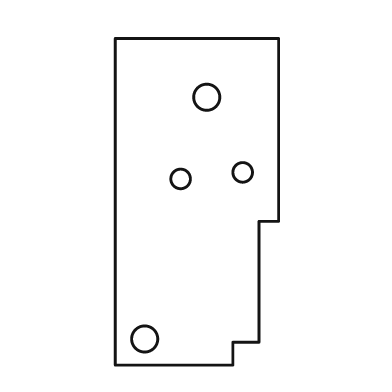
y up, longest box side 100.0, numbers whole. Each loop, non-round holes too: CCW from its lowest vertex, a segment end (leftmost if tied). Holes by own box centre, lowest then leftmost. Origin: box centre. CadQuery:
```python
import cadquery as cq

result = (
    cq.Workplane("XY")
    .moveTo(-25.0, -50.0)
    .lineTo(11.0, -50.0)
    .lineTo(11.0, -43.0)
    .lineTo(19.0, -43.0)
    .lineTo(19.0, -6.0)
    .lineTo(25.0, -6.0)
    .lineTo(25.0, 50.0)
    .lineTo(-25.0, 50.0)
    .close()
    .moveTo(-16.0, -42.0)
    .circle(4.0)
    .moveTo(-5.0, 7.0)
    .circle(3.0)
    .moveTo(14.0, 9.0)
    .circle(3.0)
    .moveTo(3.0, 32.0)
    .circle(4.0)
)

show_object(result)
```